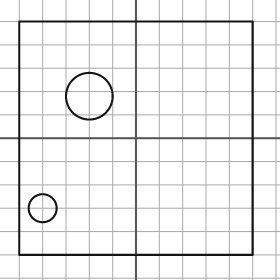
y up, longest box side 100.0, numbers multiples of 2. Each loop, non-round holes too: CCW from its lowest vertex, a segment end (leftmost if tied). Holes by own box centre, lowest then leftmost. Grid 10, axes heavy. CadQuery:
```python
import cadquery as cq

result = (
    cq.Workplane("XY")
    .moveTo(-50.0, -50.0)
    .lineTo(50.0, -50.0)
    .lineTo(50.0, 50.0)
    .lineTo(-50.0, 50.0)
    .close()
    .moveTo(-40.0, -30.0)
    .circle(6.0)
    .moveTo(-20.0, 18.0)
    .circle(10.0)
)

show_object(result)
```